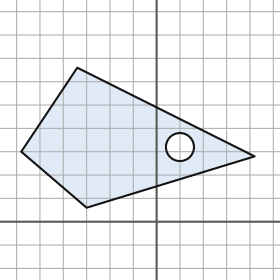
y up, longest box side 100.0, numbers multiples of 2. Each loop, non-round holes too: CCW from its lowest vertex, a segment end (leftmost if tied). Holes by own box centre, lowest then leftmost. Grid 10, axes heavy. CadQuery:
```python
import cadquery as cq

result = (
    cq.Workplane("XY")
    .moveTo(-30.0, 6.0)
    .lineTo(42.0, 28.0)
    .lineTo(-34.0, 66.0)
    .lineTo(-58.0, 30.0)
    .close()
    .moveTo(10.0, 32.0)
    .circle(6.0)
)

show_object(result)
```